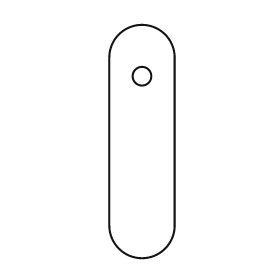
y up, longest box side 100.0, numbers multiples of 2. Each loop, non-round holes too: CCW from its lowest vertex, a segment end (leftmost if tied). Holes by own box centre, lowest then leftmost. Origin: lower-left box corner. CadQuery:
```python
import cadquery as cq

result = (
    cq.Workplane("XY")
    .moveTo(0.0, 14.0)
    .threePointArc((14.0, 0.0), (28.0, 14.0))
    .lineTo(28.0, 86.0)
    .threePointArc((14.0, 100.0), (0.0, 86.0))
    .close()
    .moveTo(14.0, 78.0)
    .circle(4.0)
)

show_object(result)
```